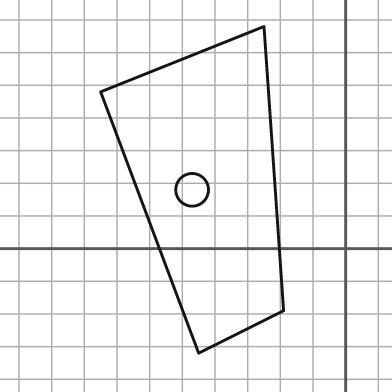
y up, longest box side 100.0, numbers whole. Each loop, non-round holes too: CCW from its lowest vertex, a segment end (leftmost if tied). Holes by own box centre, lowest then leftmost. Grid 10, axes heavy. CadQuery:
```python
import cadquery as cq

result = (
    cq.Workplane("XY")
    .moveTo(-45.0, -32.0)
    .lineTo(-19.0, -19.0)
    .lineTo(-25.0, 68.0)
    .lineTo(-75.0, 48.0)
    .close()
    .moveTo(-47.0, 18.0)
    .circle(5.0)
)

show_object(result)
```